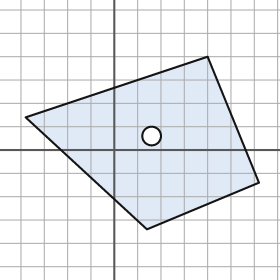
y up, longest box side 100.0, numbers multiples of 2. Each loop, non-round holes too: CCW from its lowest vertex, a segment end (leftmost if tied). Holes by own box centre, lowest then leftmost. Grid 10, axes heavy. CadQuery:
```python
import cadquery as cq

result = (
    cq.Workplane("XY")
    .moveTo(14.0, -34.0)
    .lineTo(62.0, -14.0)
    .lineTo(40.0, 40.0)
    .lineTo(-38.0, 14.0)
    .close()
    .moveTo(16.0, 6.0)
    .circle(4.0)
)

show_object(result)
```